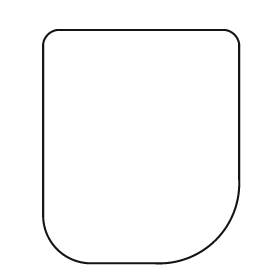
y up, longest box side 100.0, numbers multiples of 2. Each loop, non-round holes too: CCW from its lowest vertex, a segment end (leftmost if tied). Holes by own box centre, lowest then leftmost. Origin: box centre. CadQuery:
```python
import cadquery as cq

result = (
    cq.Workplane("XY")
    .moveTo(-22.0, -50.0)
    .lineTo(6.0, -50.0)
    .threePointArc((32.0, -40.0), (42.0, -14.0))
    .lineTo(42.0, 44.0)
    .threePointArc((40.0, 48.0), (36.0, 50.0))
    .lineTo(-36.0, 50.0)
    .threePointArc((-40.0, 48.0), (-42.0, 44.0))
    .lineTo(-42.0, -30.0)
    .threePointArc((-36.0, -44.0), (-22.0, -50.0))
    .close()
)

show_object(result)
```